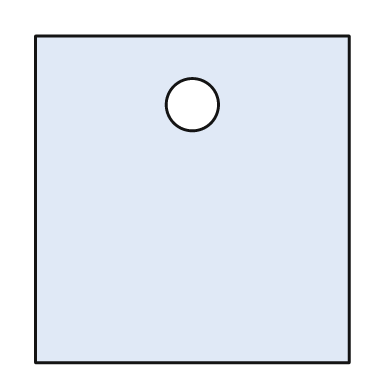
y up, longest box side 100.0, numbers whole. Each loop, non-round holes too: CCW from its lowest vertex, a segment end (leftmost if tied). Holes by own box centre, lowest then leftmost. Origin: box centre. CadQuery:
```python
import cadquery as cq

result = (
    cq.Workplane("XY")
    .moveTo(-48.0, -50.0)
    .lineTo(48.0, -50.0)
    .lineTo(48.0, 50.0)
    .lineTo(-48.0, 50.0)
    .close()
    .moveTo(0.0, 29.0)
    .circle(8.0)
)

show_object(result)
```